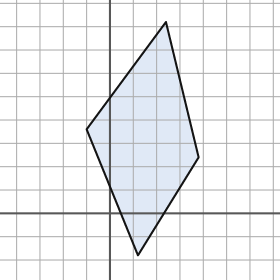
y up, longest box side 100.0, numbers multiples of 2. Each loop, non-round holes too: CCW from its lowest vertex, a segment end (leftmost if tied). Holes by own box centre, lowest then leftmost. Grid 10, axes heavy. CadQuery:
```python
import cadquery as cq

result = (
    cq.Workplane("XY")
    .moveTo(12.0, -18.0)
    .lineTo(38.0, 24.0)
    .lineTo(24.0, 82.0)
    .lineTo(-10.0, 36.0)
    .close()
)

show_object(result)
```